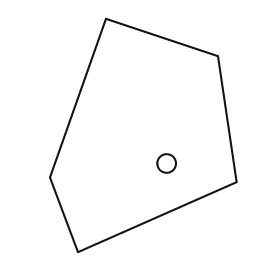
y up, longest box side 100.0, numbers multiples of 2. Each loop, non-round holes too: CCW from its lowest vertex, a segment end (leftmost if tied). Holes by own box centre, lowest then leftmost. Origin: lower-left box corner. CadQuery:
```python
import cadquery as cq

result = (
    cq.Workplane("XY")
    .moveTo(12.0, 0.0)
    .lineTo(80.0, 30.0)
    .lineTo(72.0, 84.0)
    .lineTo(24.0, 100.0)
    .lineTo(0.0, 32.0)
    .close()
    .moveTo(50.0, 38.0)
    .circle(4.0)
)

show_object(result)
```